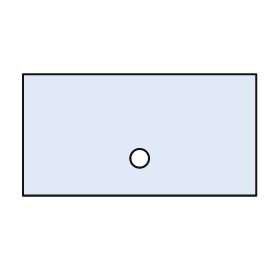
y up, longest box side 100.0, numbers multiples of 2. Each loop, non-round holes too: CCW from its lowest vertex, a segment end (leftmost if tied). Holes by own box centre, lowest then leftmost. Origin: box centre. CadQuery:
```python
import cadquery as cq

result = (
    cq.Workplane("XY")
    .moveTo(-50.0, -26.0)
    .lineTo(50.0, -26.0)
    .lineTo(50.0, 26.0)
    .lineTo(-50.0, 26.0)
    .close()
    .moveTo(0.0, -10.0)
    .circle(4.0)
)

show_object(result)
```